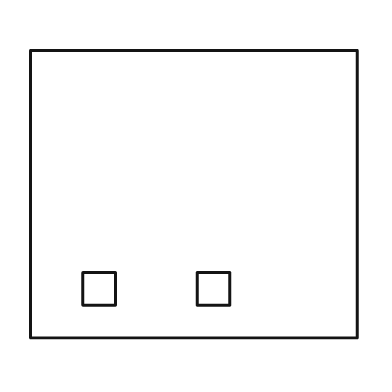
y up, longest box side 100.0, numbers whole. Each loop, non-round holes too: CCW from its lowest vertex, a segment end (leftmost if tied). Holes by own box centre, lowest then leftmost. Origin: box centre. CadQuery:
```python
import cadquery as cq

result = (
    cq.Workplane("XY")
    .moveTo(-50.0, -44.0)
    .lineTo(50.0, -44.0)
    .lineTo(50.0, 44.0)
    .lineTo(-50.0, 44.0)
    .close()
    .moveTo(-34.0, -34.0)
    .lineTo(-24.0, -34.0)
    .lineTo(-24.0, -24.0)
    .lineTo(-34.0, -24.0)
    .close()
    .moveTo(1.0, -34.0)
    .lineTo(11.0, -34.0)
    .lineTo(11.0, -24.0)
    .lineTo(1.0, -24.0)
    .close()
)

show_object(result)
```